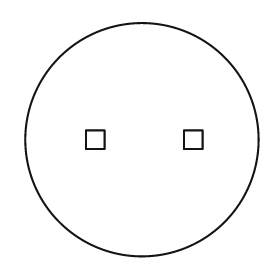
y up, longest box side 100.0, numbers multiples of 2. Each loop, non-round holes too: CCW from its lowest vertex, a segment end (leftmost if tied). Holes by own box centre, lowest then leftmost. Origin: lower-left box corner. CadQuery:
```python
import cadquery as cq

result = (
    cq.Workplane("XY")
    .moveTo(50.0, 50.0)
    .circle(50.0)
    .moveTo(26.0, 46.0)
    .lineTo(34.0, 46.0)
    .lineTo(34.0, 54.0)
    .lineTo(26.0, 54.0)
    .close()
    .moveTo(68.0, 46.0)
    .lineTo(76.0, 46.0)
    .lineTo(76.0, 54.0)
    .lineTo(68.0, 54.0)
    .close()
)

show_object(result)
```